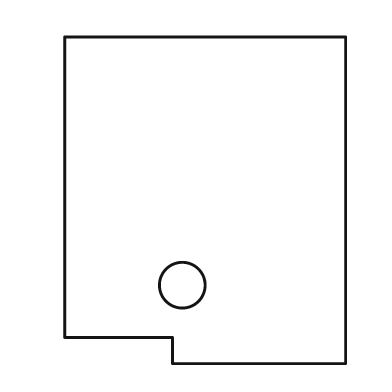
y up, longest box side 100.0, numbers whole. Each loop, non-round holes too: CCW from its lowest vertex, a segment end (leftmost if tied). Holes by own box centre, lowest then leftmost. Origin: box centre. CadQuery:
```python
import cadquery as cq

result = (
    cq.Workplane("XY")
    .moveTo(-10.0, -50.0)
    .lineTo(43.0, -50.0)
    .lineTo(43.0, 50.0)
    .lineTo(-43.0, 50.0)
    .lineTo(-43.0, -42.0)
    .lineTo(-10.0, -42.0)
    .close()
    .moveTo(-7.0, -26.0)
    .circle(7.0)
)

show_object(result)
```